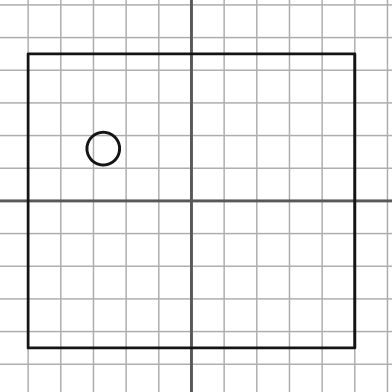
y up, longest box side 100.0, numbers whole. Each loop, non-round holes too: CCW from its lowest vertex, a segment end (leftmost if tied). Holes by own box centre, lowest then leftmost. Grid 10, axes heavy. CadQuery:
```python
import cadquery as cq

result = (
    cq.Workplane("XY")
    .moveTo(-50.0, -45.0)
    .lineTo(50.0, -45.0)
    .lineTo(50.0, 45.0)
    .lineTo(-50.0, 45.0)
    .close()
    .moveTo(-27.0, 16.0)
    .circle(5.0)
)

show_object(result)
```